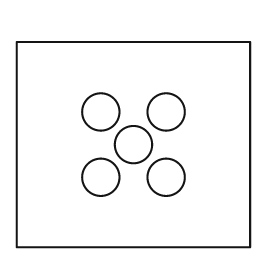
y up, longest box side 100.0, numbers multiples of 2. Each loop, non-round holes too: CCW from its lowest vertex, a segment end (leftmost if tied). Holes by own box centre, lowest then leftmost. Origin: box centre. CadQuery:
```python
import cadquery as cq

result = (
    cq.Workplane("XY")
    .moveTo(-50.0, -44.0)
    .lineTo(50.0, -44.0)
    .lineTo(50.0, 44.0)
    .lineTo(-50.0, 44.0)
    .close()
    .moveTo(-14.0, -14.0)
    .circle(8.0)
    .moveTo(14.0, -14.0)
    .circle(8.0)
    .moveTo(0.0, 0.0)
    .circle(8.0)
    .moveTo(-14.0, 14.0)
    .circle(8.0)
    .moveTo(14.0, 14.0)
    .circle(8.0)
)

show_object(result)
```